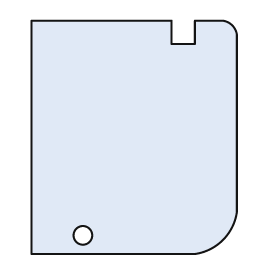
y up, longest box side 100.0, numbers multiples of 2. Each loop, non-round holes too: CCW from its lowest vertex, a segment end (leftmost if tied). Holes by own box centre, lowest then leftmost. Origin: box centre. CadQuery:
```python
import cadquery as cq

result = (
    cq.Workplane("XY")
    .moveTo(-44.0, -50.0)
    .lineTo(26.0, -50.0)
    .threePointArc((38.0, -44.0), (44.0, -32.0))
    .lineTo(44.0, 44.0)
    .threePointArc((42.0, 48.0), (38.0, 50.0))
    .lineTo(26.0, 50.0)
    .lineTo(26.0, 40.0)
    .lineTo(16.0, 40.0)
    .lineTo(16.0, 50.0)
    .lineTo(-44.0, 50.0)
    .close()
    .moveTo(-22.0, -42.0)
    .circle(4.0)
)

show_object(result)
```